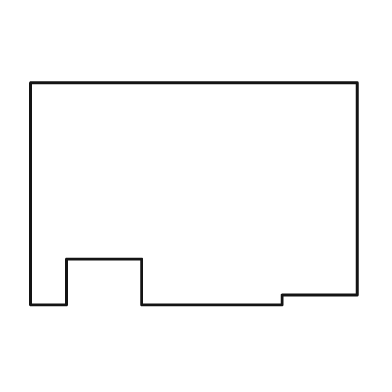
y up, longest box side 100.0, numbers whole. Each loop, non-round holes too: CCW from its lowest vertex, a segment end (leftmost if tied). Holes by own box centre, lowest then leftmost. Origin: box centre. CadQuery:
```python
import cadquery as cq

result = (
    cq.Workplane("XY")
    .moveTo(-50.0, -34.0)
    .lineTo(-39.0, -34.0)
    .lineTo(-39.0, -20.0)
    .lineTo(-16.0, -20.0)
    .lineTo(-16.0, -34.0)
    .lineTo(27.0, -34.0)
    .lineTo(27.0, -31.0)
    .lineTo(50.0, -31.0)
    .lineTo(50.0, 34.0)
    .lineTo(-50.0, 34.0)
    .close()
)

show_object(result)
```